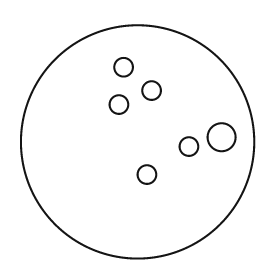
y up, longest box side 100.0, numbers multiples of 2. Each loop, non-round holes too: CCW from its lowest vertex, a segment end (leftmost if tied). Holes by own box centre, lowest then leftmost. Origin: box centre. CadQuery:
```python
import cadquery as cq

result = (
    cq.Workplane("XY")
    .moveTo(0.0, 0.0)
    .circle(50.0)
    .moveTo(4.0, -14.0)
    .circle(4.0)
    .moveTo(22.0, -2.0)
    .circle(4.0)
    .moveTo(36.0, 2.0)
    .circle(6.0)
    .moveTo(-8.0, 16.0)
    .circle(4.0)
    .moveTo(6.0, 22.0)
    .circle(4.0)
    .moveTo(-6.0, 32.0)
    .circle(4.0)
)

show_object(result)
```